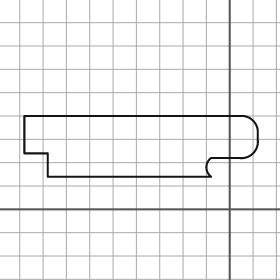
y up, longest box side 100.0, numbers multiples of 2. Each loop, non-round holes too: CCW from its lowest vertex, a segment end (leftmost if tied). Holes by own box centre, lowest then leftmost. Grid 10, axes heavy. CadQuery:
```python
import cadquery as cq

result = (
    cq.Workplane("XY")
    .moveTo(-78.0, 14.0)
    .lineTo(-8.0, 14.0)
    .threePointArc((-10.0, 18.0), (-8.0, 22.0))
    .lineTo(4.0, 22.0)
    .threePointArc((10.0, 24.0), (12.0, 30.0))
    .lineTo(12.0, 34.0)
    .threePointArc((10.0, 38.0), (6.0, 40.0))
    .lineTo(-88.0, 40.0)
    .lineTo(-88.0, 24.0)
    .lineTo(-78.0, 24.0)
    .close()
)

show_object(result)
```